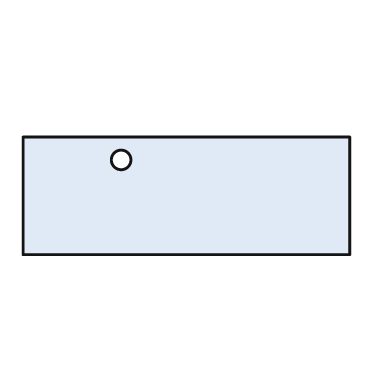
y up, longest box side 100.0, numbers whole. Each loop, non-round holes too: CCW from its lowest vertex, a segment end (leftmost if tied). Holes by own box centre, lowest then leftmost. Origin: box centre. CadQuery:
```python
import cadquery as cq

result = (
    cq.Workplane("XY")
    .moveTo(-50.0, -18.0)
    .lineTo(50.0, -18.0)
    .lineTo(50.0, 18.0)
    .lineTo(-50.0, 18.0)
    .close()
    .moveTo(-20.0, 11.0)
    .circle(3.0)
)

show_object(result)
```